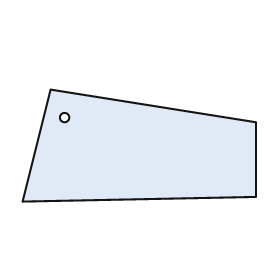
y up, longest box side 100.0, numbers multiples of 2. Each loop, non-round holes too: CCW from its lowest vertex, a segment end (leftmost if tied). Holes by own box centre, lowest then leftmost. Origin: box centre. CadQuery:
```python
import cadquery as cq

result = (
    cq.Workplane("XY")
    .moveTo(-50.0, -24.0)
    .lineTo(50.0, -22.0)
    .lineTo(50.0, 10.0)
    .lineTo(-38.0, 24.0)
    .close()
    .moveTo(-32.0, 12.0)
    .circle(2.0)
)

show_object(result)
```